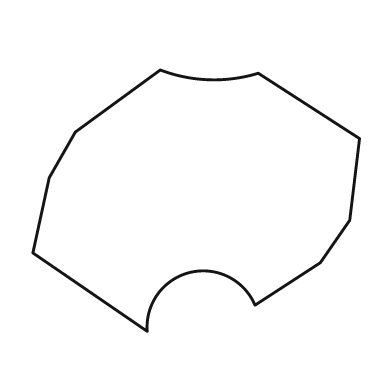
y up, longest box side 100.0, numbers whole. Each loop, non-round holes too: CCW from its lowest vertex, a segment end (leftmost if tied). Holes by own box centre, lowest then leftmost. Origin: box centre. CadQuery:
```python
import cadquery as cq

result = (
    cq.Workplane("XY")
    .moveTo(-15.0, -40.0)
    .threePointArc((-2.0, -22.0), (18.0, -32.0))
    .lineTo(38.0, -19.0)
    .lineTo(47.0, -6.0)
    .lineTo(50.0, 19.0)
    .lineTo(19.0, 39.0)
    .threePointArc((4.0, 37.0), (-11.0, 40.0))
    .lineTo(-37.0, 21.0)
    .lineTo(-45.0, 7.0)
    .lineTo(-50.0, -16.0)
    .close()
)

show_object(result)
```